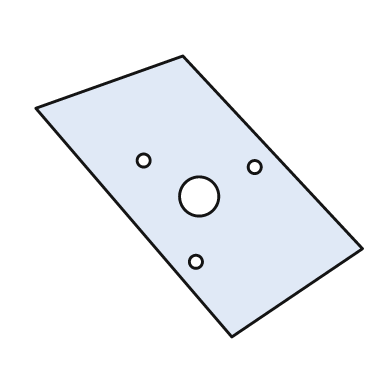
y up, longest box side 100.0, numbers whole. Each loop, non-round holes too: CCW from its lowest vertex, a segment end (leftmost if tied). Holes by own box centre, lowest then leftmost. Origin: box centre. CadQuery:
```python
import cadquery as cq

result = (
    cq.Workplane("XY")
    .moveTo(10.0, -43.0)
    .lineTo(50.0, -16.0)
    .lineTo(-5.0, 43.0)
    .lineTo(-50.0, 27.0)
    .close()
    .moveTo(-1.0, -20.0)
    .circle(2.0)
    .moveTo(0.0, 0.0)
    .circle(6.0)
    .moveTo(17.0, 9.0)
    .circle(2.0)
    .moveTo(-17.0, 11.0)
    .circle(2.0)
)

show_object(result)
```